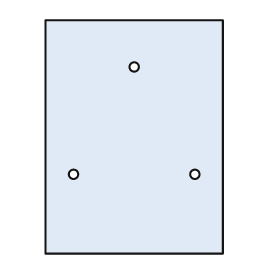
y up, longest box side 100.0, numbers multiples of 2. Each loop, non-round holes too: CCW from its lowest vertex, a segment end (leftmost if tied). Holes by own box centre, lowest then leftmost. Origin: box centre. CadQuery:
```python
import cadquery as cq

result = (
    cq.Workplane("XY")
    .moveTo(-38.0, -50.0)
    .lineTo(38.0, -50.0)
    .lineTo(38.0, 50.0)
    .lineTo(-38.0, 50.0)
    .close()
    .moveTo(-26.0, -16.0)
    .circle(2.0)
    .moveTo(26.0, -16.0)
    .circle(2.0)
    .moveTo(0.0, 30.0)
    .circle(2.0)
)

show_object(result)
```